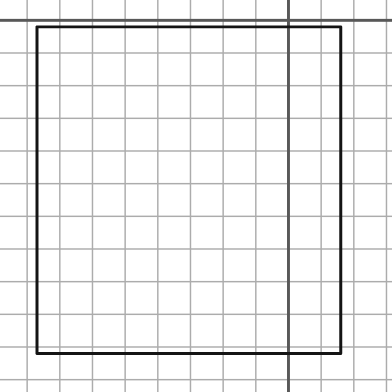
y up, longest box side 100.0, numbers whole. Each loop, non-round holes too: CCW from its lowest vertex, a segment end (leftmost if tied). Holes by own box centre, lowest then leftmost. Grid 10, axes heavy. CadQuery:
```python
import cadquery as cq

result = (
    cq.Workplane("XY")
    .moveTo(-77.0, -102.0)
    .lineTo(16.0, -102.0)
    .lineTo(16.0, -2.0)
    .lineTo(-77.0, -2.0)
    .close()
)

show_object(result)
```